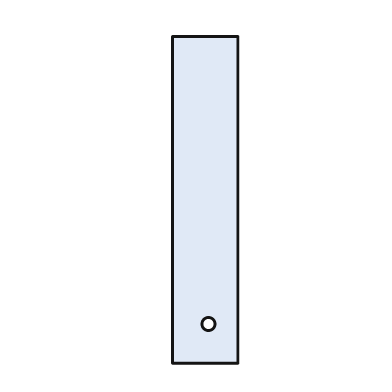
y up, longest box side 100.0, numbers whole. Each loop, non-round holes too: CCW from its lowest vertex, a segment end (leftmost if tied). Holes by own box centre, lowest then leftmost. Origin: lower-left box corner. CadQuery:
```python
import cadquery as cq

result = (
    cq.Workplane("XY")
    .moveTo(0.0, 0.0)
    .lineTo(20.0, 0.0)
    .lineTo(20.0, 100.0)
    .lineTo(0.0, 100.0)
    .close()
    .moveTo(11.0, 12.0)
    .circle(2.0)
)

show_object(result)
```